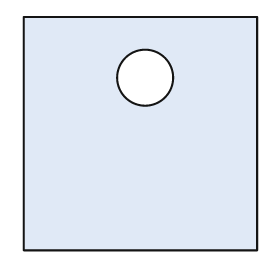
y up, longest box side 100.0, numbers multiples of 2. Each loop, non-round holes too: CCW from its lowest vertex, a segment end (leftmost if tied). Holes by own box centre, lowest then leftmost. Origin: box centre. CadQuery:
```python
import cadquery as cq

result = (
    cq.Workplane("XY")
    .moveTo(-50.0, -50.0)
    .lineTo(50.0, -50.0)
    .lineTo(50.0, 50.0)
    .lineTo(-50.0, 50.0)
    .close()
    .moveTo(2.0, 24.0)
    .circle(12.0)
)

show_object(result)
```